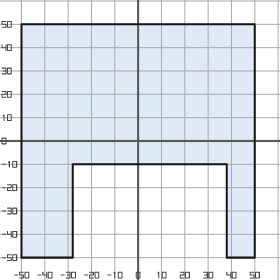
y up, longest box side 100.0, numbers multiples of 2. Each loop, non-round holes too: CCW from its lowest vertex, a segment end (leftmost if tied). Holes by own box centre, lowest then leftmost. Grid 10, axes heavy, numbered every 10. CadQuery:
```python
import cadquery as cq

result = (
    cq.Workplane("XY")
    .moveTo(-50.0, -50.0)
    .lineTo(-28.0, -50.0)
    .lineTo(-28.0, -10.0)
    .lineTo(38.0, -10.0)
    .lineTo(38.0, -50.0)
    .lineTo(50.0, -50.0)
    .lineTo(50.0, 50.0)
    .lineTo(-50.0, 50.0)
    .close()
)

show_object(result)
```